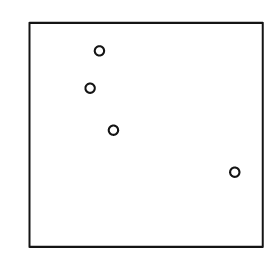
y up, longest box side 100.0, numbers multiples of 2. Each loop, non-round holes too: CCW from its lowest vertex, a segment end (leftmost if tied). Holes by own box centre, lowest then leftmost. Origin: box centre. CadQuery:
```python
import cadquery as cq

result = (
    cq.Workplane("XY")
    .moveTo(-50.0, -48.0)
    .lineTo(50.0, -48.0)
    .lineTo(50.0, 48.0)
    .lineTo(-50.0, 48.0)
    .close()
    .moveTo(38.0, -16.0)
    .circle(2.0)
    .moveTo(-14.0, 2.0)
    .circle(2.0)
    .moveTo(-24.0, 20.0)
    .circle(2.0)
    .moveTo(-20.0, 36.0)
    .circle(2.0)
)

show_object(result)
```